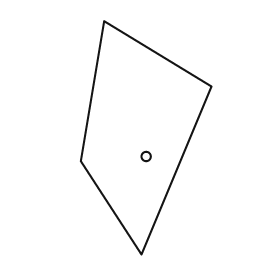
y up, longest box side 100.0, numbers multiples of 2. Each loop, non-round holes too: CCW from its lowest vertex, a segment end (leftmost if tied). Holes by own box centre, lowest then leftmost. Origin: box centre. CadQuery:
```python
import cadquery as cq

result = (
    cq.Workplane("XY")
    .moveTo(-2.0, -50.0)
    .lineTo(28.0, 22.0)
    .lineTo(-18.0, 50.0)
    .lineTo(-28.0, -10.0)
    .close()
    .moveTo(0.0, -8.0)
    .circle(2.0)
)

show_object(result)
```